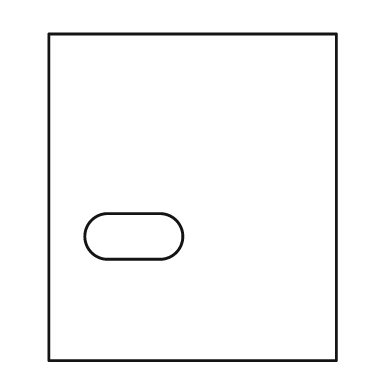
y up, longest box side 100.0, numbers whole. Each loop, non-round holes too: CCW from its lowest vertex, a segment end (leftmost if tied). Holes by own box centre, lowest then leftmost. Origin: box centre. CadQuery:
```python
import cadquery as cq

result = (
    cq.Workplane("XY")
    .moveTo(-44.0, -50.0)
    .lineTo(44.0, -50.0)
    .lineTo(44.0, 50.0)
    .lineTo(-44.0, 50.0)
    .close()
    .moveTo(-26.0, -19.0)
    .lineTo(-10.0, -19.0)
    .threePointArc((-3.0, -12.0), (-10.0, -5.0))
    .lineTo(-26.0, -5.0)
    .threePointArc((-33.0, -12.0), (-26.0, -19.0))
    .close()
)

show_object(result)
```